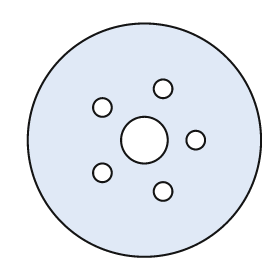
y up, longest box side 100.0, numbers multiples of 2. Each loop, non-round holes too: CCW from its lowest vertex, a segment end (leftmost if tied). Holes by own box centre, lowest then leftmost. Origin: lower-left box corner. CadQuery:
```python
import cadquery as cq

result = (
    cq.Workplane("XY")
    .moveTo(50.0, 50.0)
    .circle(50.0)
    .moveTo(58.0, 28.0)
    .circle(4.0)
    .moveTo(32.0, 36.0)
    .circle(4.0)
    .moveTo(50.0, 50.0)
    .circle(10.0)
    .moveTo(72.0, 50.0)
    .circle(4.0)
    .moveTo(32.0, 64.0)
    .circle(4.0)
    .moveTo(58.0, 72.0)
    .circle(4.0)
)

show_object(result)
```